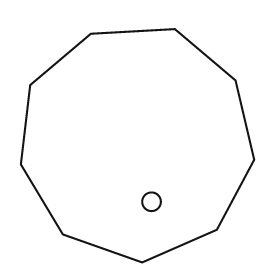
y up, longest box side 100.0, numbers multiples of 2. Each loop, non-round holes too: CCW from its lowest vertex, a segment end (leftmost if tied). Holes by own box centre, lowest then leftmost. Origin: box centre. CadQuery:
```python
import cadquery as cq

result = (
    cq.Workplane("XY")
    .moveTo(2.0, -50.0)
    .lineTo(34.0, -36.0)
    .lineTo(50.0, -6.0)
    .lineTo(42.0, 28.0)
    .lineTo(16.0, 50.0)
    .lineTo(-20.0, 48.0)
    .lineTo(-46.0, 26.0)
    .lineTo(-50.0, -8.0)
    .lineTo(-32.0, -38.0)
    .close()
    .moveTo(6.0, -24.0)
    .circle(4.0)
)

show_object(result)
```